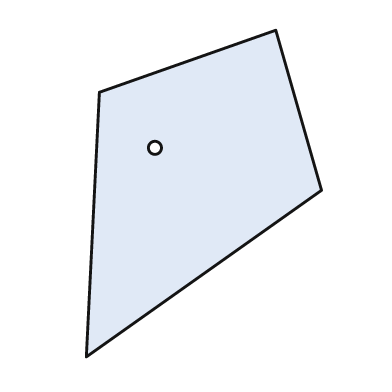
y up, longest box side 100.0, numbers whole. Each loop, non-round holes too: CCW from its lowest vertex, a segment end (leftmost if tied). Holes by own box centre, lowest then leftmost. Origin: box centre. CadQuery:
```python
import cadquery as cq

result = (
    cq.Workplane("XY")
    .moveTo(-36.0, -50.0)
    .lineTo(36.0, 1.0)
    .lineTo(22.0, 50.0)
    .lineTo(-32.0, 31.0)
    .close()
    .moveTo(-15.0, 14.0)
    .circle(2.0)
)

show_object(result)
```